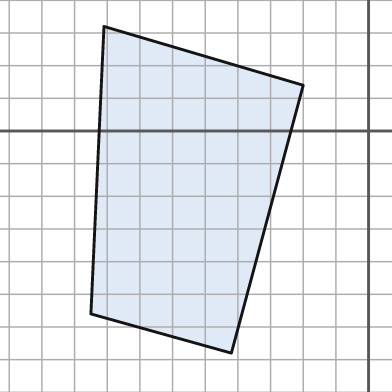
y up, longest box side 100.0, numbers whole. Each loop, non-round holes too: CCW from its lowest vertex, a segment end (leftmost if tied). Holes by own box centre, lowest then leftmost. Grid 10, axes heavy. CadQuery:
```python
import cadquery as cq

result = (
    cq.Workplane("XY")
    .moveTo(-42.0, -68.0)
    .lineTo(-20.0, 14.0)
    .lineTo(-81.0, 32.0)
    .lineTo(-85.0, -56.0)
    .close()
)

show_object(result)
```